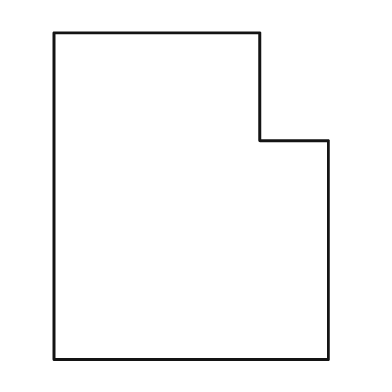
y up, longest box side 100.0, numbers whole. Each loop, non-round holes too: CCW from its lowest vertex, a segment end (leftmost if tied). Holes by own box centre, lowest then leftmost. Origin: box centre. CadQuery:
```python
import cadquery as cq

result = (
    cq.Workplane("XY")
    .moveTo(-42.0, -50.0)
    .lineTo(42.0, -50.0)
    .lineTo(42.0, 17.0)
    .lineTo(21.0, 17.0)
    .lineTo(21.0, 50.0)
    .lineTo(-42.0, 50.0)
    .close()
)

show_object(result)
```